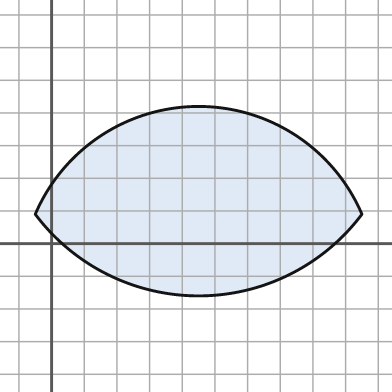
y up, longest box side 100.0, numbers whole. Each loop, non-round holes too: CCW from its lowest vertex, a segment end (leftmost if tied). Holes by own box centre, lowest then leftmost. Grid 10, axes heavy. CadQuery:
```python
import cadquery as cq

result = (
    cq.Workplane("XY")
    .moveTo(-5.0, 9.0)
    .threePointArc((45.0, -16.0), (95.0, 9.0))
    .threePointArc((45.0, 42.0), (-5.0, 9.0))
    .close()
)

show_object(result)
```